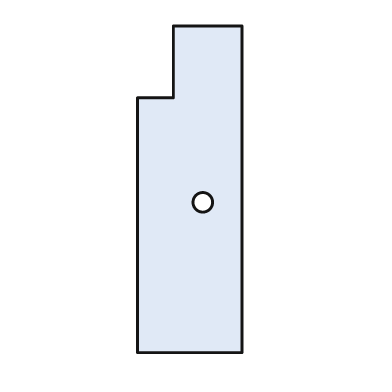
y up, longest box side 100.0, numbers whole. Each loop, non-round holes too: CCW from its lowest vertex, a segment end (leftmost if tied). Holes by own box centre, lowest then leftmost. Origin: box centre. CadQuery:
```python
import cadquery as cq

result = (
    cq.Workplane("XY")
    .moveTo(-16.0, -50.0)
    .lineTo(16.0, -50.0)
    .lineTo(16.0, 50.0)
    .lineTo(-5.0, 50.0)
    .lineTo(-5.0, 28.0)
    .lineTo(-16.0, 28.0)
    .close()
    .moveTo(4.0, -4.0)
    .circle(3.0)
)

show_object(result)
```